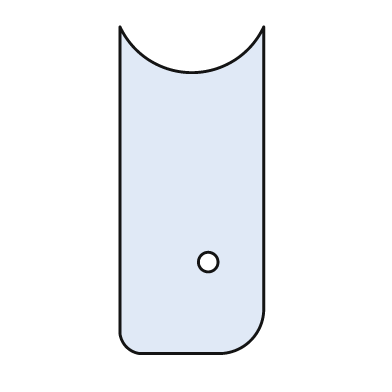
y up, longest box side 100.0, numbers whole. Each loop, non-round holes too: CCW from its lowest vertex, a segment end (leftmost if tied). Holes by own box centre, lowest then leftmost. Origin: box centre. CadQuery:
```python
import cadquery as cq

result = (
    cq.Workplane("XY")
    .moveTo(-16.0, -50.0)
    .lineTo(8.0, -50.0)
    .threePointArc((18.0, -46.0), (22.0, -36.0))
    .lineTo(22.0, 50.0)
    .threePointArc((0.0, 36.0), (-22.0, 50.0))
    .lineTo(-22.0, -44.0)
    .threePointArc((-20.0, -48.0), (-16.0, -50.0))
    .close()
    .moveTo(5.0, -22.0)
    .circle(3.0)
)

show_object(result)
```